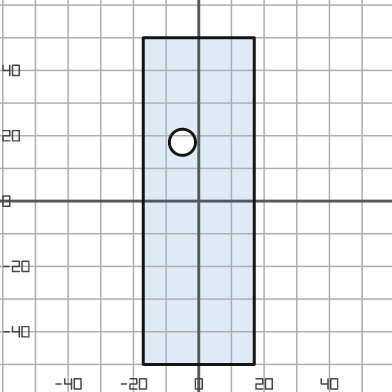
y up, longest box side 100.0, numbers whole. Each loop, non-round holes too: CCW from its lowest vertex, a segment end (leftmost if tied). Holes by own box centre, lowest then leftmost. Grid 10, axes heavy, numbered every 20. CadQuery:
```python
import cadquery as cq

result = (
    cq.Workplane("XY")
    .moveTo(-17.0, -50.0)
    .lineTo(17.0, -50.0)
    .lineTo(17.0, 50.0)
    .lineTo(-17.0, 50.0)
    .close()
    .moveTo(-5.0, 18.0)
    .circle(4.0)
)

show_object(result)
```